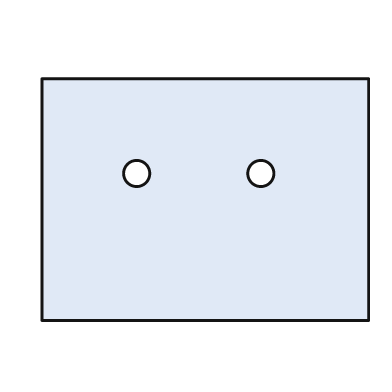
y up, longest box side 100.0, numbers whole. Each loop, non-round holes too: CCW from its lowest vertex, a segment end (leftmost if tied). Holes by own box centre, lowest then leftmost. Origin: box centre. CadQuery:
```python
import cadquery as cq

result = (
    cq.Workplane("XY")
    .moveTo(-50.0, -37.0)
    .lineTo(50.0, -37.0)
    .lineTo(50.0, 37.0)
    .lineTo(-50.0, 37.0)
    .close()
    .moveTo(-21.0, 8.0)
    .circle(4.0)
    .moveTo(17.0, 8.0)
    .circle(4.0)
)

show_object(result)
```